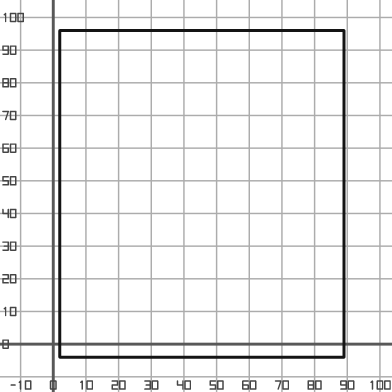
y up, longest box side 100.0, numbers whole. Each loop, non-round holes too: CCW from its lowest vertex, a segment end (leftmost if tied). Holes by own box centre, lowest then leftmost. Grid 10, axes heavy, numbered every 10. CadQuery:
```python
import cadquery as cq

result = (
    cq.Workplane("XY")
    .moveTo(2.0, -4.0)
    .lineTo(89.0, -4.0)
    .lineTo(89.0, 96.0)
    .lineTo(2.0, 96.0)
    .close()
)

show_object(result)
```